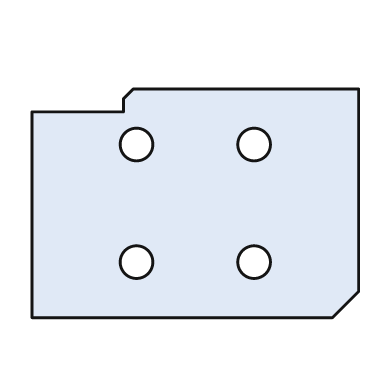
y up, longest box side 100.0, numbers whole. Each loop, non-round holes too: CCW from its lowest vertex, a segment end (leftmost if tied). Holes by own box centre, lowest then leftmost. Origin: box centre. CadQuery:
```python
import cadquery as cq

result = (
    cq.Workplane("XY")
    .moveTo(-50.0, -35.0)
    .lineTo(42.0, -35.0)
    .lineTo(50.0, -27.0)
    .lineTo(50.0, 35.0)
    .lineTo(-19.0, 35.0)
    .lineTo(-22.0, 32.0)
    .lineTo(-22.0, 28.0)
    .lineTo(-50.0, 28.0)
    .close()
    .moveTo(-18.0, -18.0)
    .circle(5.0)
    .moveTo(18.0, -18.0)
    .circle(5.0)
    .moveTo(-18.0, 18.0)
    .circle(5.0)
    .moveTo(18.0, 18.0)
    .circle(5.0)
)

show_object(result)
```